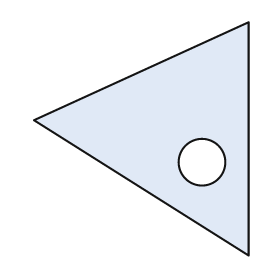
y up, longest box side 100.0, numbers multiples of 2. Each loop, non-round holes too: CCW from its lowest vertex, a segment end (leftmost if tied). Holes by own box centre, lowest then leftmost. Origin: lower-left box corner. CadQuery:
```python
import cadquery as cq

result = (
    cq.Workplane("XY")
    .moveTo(92.0, 0.0)
    .lineTo(92.0, 100.0)
    .lineTo(0.0, 58.0)
    .close()
    .moveTo(72.0, 40.0)
    .circle(10.0)
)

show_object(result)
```